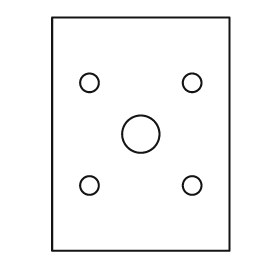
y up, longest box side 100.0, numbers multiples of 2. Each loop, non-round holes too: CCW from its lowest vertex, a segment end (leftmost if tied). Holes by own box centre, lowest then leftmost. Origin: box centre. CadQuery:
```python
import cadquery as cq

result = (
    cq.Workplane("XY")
    .moveTo(-38.0, -50.0)
    .lineTo(38.0, -50.0)
    .lineTo(38.0, 50.0)
    .lineTo(-38.0, 50.0)
    .close()
    .moveTo(-22.0, -22.0)
    .circle(4.0)
    .moveTo(22.0, -22.0)
    .circle(4.0)
    .moveTo(0.0, 0.0)
    .circle(8.0)
    .moveTo(-22.0, 22.0)
    .circle(4.0)
    .moveTo(22.0, 22.0)
    .circle(4.0)
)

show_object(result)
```